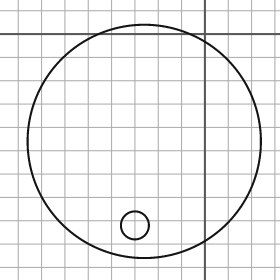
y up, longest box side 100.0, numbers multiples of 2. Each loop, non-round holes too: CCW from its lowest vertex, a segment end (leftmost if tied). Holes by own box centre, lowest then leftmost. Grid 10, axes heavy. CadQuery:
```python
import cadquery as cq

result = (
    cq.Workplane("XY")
    .moveTo(-26.0, -46.0)
    .circle(50.0)
    .moveTo(-30.0, -82.0)
    .circle(6.0)
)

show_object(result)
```